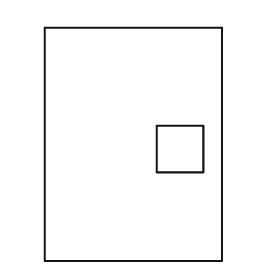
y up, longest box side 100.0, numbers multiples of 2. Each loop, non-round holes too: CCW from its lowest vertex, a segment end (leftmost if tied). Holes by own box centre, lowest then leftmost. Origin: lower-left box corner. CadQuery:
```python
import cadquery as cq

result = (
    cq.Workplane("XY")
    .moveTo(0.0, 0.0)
    .lineTo(76.0, 0.0)
    .lineTo(76.0, 100.0)
    .lineTo(0.0, 100.0)
    .close()
    .moveTo(48.0, 38.0)
    .lineTo(68.0, 38.0)
    .lineTo(68.0, 58.0)
    .lineTo(48.0, 58.0)
    .close()
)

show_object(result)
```